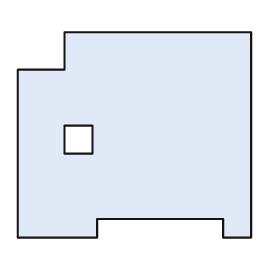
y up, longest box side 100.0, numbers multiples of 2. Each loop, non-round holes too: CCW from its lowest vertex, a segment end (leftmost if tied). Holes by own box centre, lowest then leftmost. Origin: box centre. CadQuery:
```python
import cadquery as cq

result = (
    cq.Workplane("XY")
    .moveTo(-50.0, -44.0)
    .lineTo(-16.0, -44.0)
    .lineTo(-16.0, -36.0)
    .lineTo(38.0, -36.0)
    .lineTo(38.0, -44.0)
    .lineTo(50.0, -44.0)
    .lineTo(50.0, 44.0)
    .lineTo(-30.0, 44.0)
    .lineTo(-30.0, 28.0)
    .lineTo(-50.0, 28.0)
    .close()
    .moveTo(-30.0, -8.0)
    .lineTo(-18.0, -8.0)
    .lineTo(-18.0, 4.0)
    .lineTo(-30.0, 4.0)
    .close()
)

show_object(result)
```